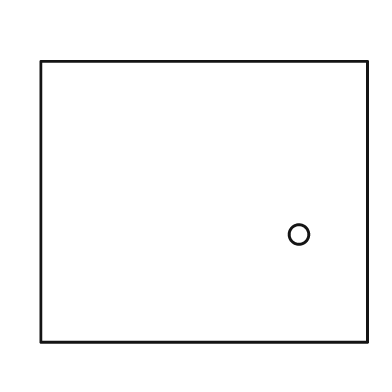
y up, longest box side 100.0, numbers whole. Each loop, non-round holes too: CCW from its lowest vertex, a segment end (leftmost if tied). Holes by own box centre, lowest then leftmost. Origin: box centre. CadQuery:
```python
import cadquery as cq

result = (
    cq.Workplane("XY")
    .moveTo(-50.0, -43.0)
    .lineTo(50.0, -43.0)
    .lineTo(50.0, 43.0)
    .lineTo(-50.0, 43.0)
    .close()
    .moveTo(29.0, -10.0)
    .circle(3.0)
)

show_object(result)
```